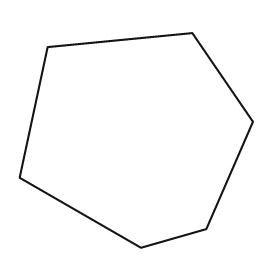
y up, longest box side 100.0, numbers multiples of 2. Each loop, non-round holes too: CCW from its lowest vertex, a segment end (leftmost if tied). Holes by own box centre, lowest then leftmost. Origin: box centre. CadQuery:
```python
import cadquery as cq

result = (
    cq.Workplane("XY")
    .moveTo(2.0, -46.0)
    .lineTo(30.0, -38.0)
    .lineTo(50.0, 8.0)
    .lineTo(24.0, 46.0)
    .lineTo(-38.0, 40.0)
    .lineTo(-50.0, -16.0)
    .close()
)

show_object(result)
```